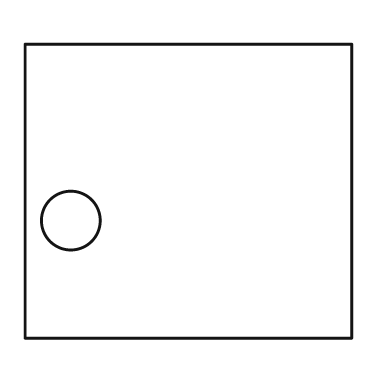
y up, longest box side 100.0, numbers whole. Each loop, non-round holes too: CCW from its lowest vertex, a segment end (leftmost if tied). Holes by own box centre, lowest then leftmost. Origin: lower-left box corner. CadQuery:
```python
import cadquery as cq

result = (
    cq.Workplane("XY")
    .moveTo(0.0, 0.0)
    .lineTo(100.0, 0.0)
    .lineTo(100.0, 90.0)
    .lineTo(0.0, 90.0)
    .close()
    .moveTo(14.0, 36.0)
    .circle(9.0)
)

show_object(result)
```